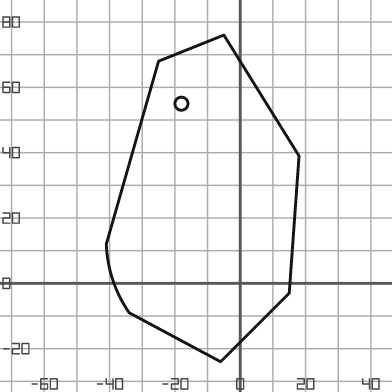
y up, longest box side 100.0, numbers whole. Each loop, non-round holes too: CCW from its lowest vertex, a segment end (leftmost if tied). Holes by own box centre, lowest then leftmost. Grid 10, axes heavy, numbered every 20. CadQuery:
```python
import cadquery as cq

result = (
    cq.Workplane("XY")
    .moveTo(-6.0, -24.0)
    .lineTo(15.0, -3.0)
    .lineTo(18.0, 39.0)
    .lineTo(-5.0, 76.0)
    .lineTo(-25.0, 68.0)
    .lineTo(-41.0, 12.0)
    .threePointArc((-39.0, 1.0), (-34.0, -9.0))
    .close()
    .moveTo(-18.0, 55.0)
    .circle(2.0)
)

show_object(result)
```